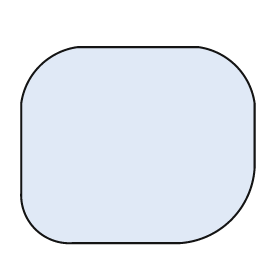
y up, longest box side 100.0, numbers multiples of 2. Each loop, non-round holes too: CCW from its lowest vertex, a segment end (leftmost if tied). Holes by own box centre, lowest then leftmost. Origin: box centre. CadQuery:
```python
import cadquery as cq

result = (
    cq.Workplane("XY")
    .moveTo(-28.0, -42.0)
    .lineTo(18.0, -42.0)
    .threePointArc((40.0, -32.0), (50.0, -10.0))
    .lineTo(50.0, 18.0)
    .threePointArc((42.0, 34.0), (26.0, 42.0))
    .lineTo(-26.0, 42.0)
    .threePointArc((-42.0, 34.0), (-50.0, 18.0))
    .lineTo(-50.0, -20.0)
    .threePointArc((-44.0, -36.0), (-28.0, -42.0))
    .close()
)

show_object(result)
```